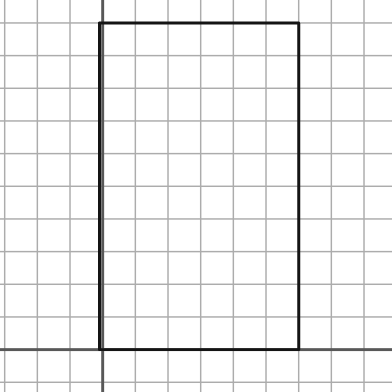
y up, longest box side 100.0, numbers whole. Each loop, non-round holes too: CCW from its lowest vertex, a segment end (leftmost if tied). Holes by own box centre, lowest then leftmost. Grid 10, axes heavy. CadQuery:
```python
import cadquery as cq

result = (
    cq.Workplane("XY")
    .moveTo(-1.0, 0.0)
    .lineTo(60.0, 0.0)
    .lineTo(60.0, 100.0)
    .lineTo(-1.0, 100.0)
    .close()
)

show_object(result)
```